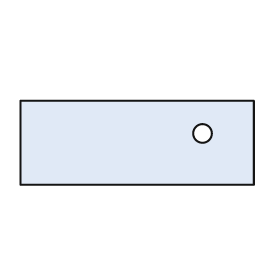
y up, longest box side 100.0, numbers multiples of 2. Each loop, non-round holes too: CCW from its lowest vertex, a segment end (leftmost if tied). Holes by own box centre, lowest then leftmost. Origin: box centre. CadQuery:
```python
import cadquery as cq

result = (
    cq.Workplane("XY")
    .moveTo(-50.0, -18.0)
    .lineTo(50.0, -18.0)
    .lineTo(50.0, 18.0)
    .lineTo(-50.0, 18.0)
    .close()
    .moveTo(28.0, 4.0)
    .circle(4.0)
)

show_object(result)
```